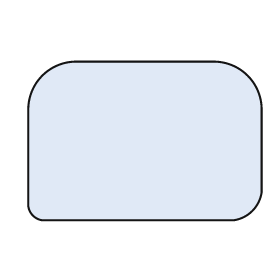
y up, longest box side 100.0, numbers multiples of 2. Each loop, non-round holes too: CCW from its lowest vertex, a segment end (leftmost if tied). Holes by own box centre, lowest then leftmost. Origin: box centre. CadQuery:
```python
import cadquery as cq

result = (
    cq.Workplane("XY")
    .moveTo(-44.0, -34.0)
    .lineTo(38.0, -34.0)
    .threePointArc((46.0, -30.0), (50.0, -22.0))
    .lineTo(50.0, 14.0)
    .threePointArc((44.0, 28.0), (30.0, 34.0))
    .lineTo(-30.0, 34.0)
    .threePointArc((-44.0, 28.0), (-50.0, 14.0))
    .lineTo(-50.0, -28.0)
    .threePointArc((-48.0, -32.0), (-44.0, -34.0))
    .close()
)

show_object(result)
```